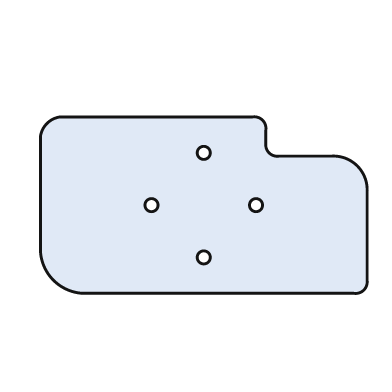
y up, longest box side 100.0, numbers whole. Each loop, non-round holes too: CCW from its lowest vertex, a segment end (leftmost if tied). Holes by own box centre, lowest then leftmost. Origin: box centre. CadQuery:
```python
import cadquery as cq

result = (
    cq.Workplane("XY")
    .moveTo(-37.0, -27.0)
    .lineTo(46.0, -27.0)
    .threePointArc((49.0, -26.0), (50.0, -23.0))
    .lineTo(50.0, 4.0)
    .threePointArc((47.0, 12.0), (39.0, 15.0))
    .lineTo(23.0, 15.0)
    .threePointArc((20.0, 16.0), (19.0, 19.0))
    .lineTo(19.0, 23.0)
    .threePointArc((18.0, 26.0), (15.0, 27.0))
    .lineTo(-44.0, 27.0)
    .threePointArc((-48.0, 25.0), (-50.0, 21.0))
    .lineTo(-50.0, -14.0)
    .threePointArc((-46.0, -23.0), (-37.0, -27.0))
    .close()
    .moveTo(0.0, -16.0)
    .circle(2.0)
    .moveTo(-16.0, 0.0)
    .circle(2.0)
    .moveTo(16.0, 0.0)
    .circle(2.0)
    .moveTo(0.0, 16.0)
    .circle(2.0)
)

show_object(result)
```